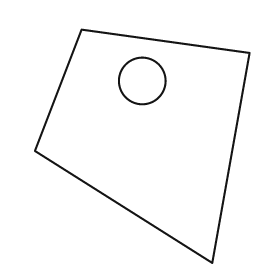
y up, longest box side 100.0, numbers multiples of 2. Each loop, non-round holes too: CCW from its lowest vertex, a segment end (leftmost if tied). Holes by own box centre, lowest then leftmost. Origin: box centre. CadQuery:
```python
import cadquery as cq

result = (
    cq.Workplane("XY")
    .moveTo(30.0, -50.0)
    .lineTo(46.0, 40.0)
    .lineTo(-26.0, 50.0)
    .lineTo(-46.0, -2.0)
    .close()
    .moveTo(0.0, 28.0)
    .circle(10.0)
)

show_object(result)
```